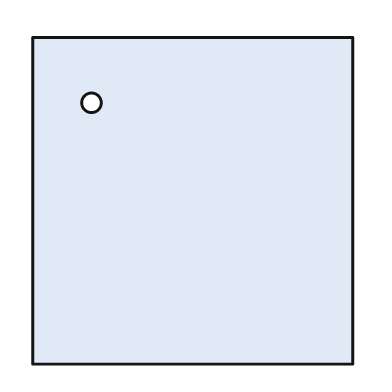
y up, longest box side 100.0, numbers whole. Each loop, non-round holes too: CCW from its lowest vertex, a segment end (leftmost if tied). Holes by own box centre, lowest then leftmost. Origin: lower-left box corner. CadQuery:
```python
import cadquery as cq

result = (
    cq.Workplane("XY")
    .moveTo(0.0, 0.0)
    .lineTo(98.0, 0.0)
    .lineTo(98.0, 100.0)
    .lineTo(0.0, 100.0)
    .close()
    .moveTo(18.0, 80.0)
    .circle(3.0)
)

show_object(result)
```